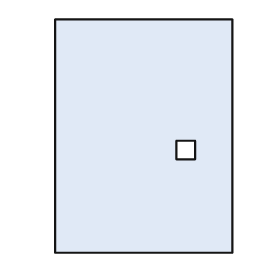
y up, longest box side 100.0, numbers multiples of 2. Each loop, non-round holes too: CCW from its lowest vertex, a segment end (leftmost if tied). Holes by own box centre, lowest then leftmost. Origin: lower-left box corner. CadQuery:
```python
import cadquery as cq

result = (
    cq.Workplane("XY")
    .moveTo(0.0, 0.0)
    .lineTo(76.0, 0.0)
    .lineTo(76.0, 100.0)
    .lineTo(0.0, 100.0)
    .close()
    .moveTo(52.0, 40.0)
    .lineTo(60.0, 40.0)
    .lineTo(60.0, 48.0)
    .lineTo(52.0, 48.0)
    .close()
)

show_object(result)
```